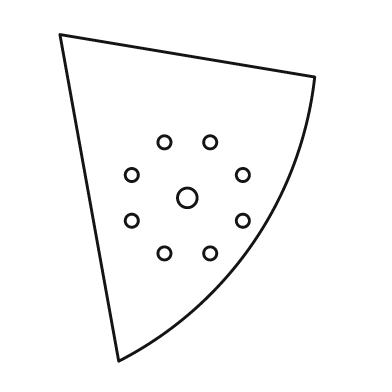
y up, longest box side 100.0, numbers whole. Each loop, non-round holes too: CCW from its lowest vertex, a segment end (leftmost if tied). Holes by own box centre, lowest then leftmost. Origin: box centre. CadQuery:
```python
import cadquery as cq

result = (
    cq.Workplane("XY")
    .moveTo(-21.0, -50.0)
    .threePointArc((20.0, -14.0), (39.0, 37.0))
    .lineTo(-39.0, 50.0)
    .close()
    .moveTo(-7.0, -17.0)
    .circle(2.0)
    .moveTo(7.0, -17.0)
    .circle(2.0)
    .moveTo(-17.0, -7.0)
    .circle(2.0)
    .moveTo(17.0, -7.0)
    .circle(2.0)
    .moveTo(0.0, 0.0)
    .circle(3.0)
    .moveTo(-17.0, 7.0)
    .circle(2.0)
    .moveTo(17.0, 7.0)
    .circle(2.0)
    .moveTo(-7.0, 17.0)
    .circle(2.0)
    .moveTo(7.0, 17.0)
    .circle(2.0)
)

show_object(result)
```